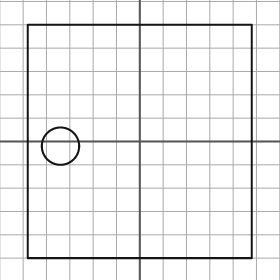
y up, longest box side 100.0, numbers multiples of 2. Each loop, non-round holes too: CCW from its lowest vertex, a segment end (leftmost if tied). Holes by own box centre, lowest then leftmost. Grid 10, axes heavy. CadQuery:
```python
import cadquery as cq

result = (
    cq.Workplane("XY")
    .moveTo(-48.0, -50.0)
    .lineTo(48.0, -50.0)
    .lineTo(48.0, 50.0)
    .lineTo(-48.0, 50.0)
    .close()
    .moveTo(-34.0, -2.0)
    .circle(8.0)
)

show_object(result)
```